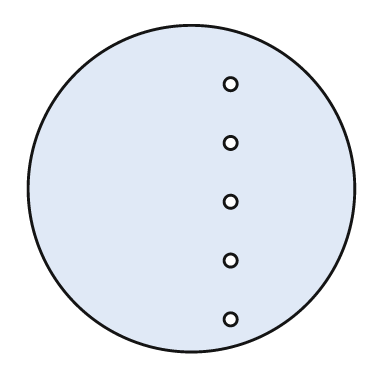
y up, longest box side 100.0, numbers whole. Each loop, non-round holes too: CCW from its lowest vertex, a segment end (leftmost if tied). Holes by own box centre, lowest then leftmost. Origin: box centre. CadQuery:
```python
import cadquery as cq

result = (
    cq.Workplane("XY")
    .moveTo(0.0, 0.0)
    .circle(50.0)
    .moveTo(12.0, -40.0)
    .circle(2.0)
    .moveTo(12.0, -22.0)
    .circle(2.0)
    .moveTo(12.0, -4.0)
    .circle(2.0)
    .moveTo(12.0, 14.0)
    .circle(2.0)
    .moveTo(12.0, 32.0)
    .circle(2.0)
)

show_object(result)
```